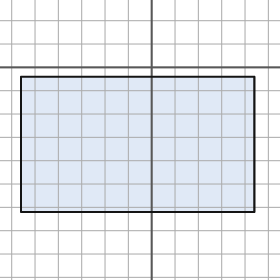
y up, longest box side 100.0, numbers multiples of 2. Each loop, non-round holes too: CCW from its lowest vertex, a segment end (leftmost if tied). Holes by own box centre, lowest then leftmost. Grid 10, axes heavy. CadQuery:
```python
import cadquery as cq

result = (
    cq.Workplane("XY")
    .moveTo(-56.0, -62.0)
    .lineTo(44.0, -62.0)
    .lineTo(44.0, -4.0)
    .lineTo(-56.0, -4.0)
    .close()
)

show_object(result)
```